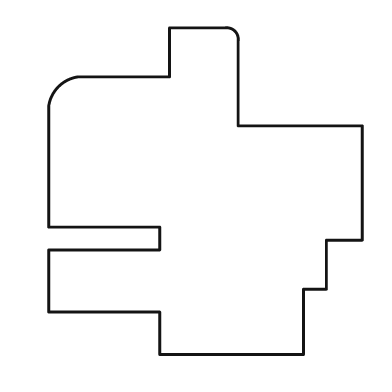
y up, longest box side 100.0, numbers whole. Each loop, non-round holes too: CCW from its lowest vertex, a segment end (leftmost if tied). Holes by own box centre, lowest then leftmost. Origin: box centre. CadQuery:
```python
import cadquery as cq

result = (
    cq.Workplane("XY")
    .moveTo(-14.0, -50.0)
    .lineTo(30.0, -50.0)
    .lineTo(30.0, -30.0)
    .lineTo(37.0, -30.0)
    .lineTo(37.0, -15.0)
    .lineTo(48.0, -15.0)
    .lineTo(48.0, 20.0)
    .lineTo(10.0, 20.0)
    .lineTo(10.0, 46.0)
    .threePointArc((9.0, 49.0), (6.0, 50.0))
    .lineTo(-11.0, 50.0)
    .lineTo(-11.0, 35.0)
    .lineTo(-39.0, 35.0)
    .threePointArc((-45.0, 32.0), (-48.0, 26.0))
    .lineTo(-48.0, -11.0)
    .lineTo(-14.0, -11.0)
    .lineTo(-14.0, -18.0)
    .lineTo(-48.0, -18.0)
    .lineTo(-48.0, -37.0)
    .lineTo(-14.0, -37.0)
    .close()
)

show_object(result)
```